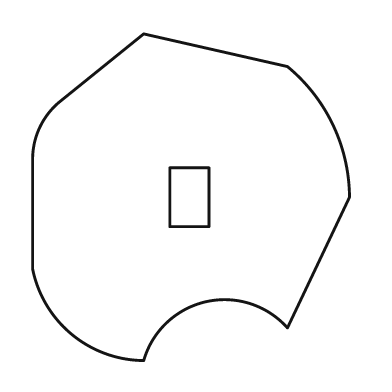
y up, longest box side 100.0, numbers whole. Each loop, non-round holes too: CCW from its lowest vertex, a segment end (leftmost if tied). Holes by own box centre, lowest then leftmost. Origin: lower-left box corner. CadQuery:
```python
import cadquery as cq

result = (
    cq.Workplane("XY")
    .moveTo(34.0, 0.0)
    .threePointArc((53.0, 18.0), (78.0, 10.0))
    .lineTo(97.0, 50.0)
    .threePointArc((92.0, 72.0), (78.0, 90.0))
    .lineTo(34.0, 100.0)
    .lineTo(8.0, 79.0)
    .threePointArc((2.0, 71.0), (0.0, 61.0))
    .lineTo(0.0, 28.0)
    .threePointArc((12.0, 8.0), (34.0, 0.0))
    .close()
    .moveTo(42.0, 41.0)
    .lineTo(54.0, 41.0)
    .lineTo(54.0, 59.0)
    .lineTo(42.0, 59.0)
    .close()
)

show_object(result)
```